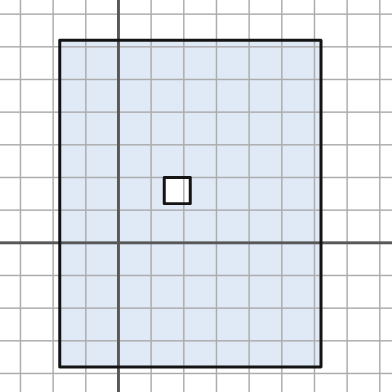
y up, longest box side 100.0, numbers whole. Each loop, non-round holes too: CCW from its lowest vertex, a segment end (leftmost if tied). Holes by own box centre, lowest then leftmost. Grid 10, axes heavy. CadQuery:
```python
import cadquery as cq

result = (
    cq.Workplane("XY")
    .moveTo(-18.0, -38.0)
    .lineTo(62.0, -38.0)
    .lineTo(62.0, 62.0)
    .lineTo(-18.0, 62.0)
    .close()
    .moveTo(14.0, 12.0)
    .lineTo(22.0, 12.0)
    .lineTo(22.0, 20.0)
    .lineTo(14.0, 20.0)
    .close()
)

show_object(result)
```